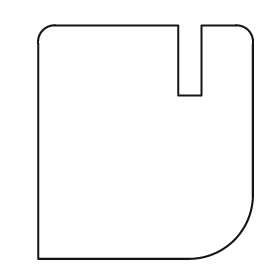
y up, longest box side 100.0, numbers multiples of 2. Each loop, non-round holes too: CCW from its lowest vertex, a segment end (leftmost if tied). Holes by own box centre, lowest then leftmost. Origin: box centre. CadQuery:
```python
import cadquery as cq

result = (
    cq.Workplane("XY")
    .moveTo(-46.0, -50.0)
    .lineTo(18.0, -50.0)
    .threePointArc((38.0, -42.0), (46.0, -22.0))
    .lineTo(46.0, 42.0)
    .threePointArc((44.0, 48.0), (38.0, 50.0))
    .lineTo(24.0, 50.0)
    .lineTo(24.0, 20.0)
    .lineTo(14.0, 20.0)
    .lineTo(14.0, 50.0)
    .lineTo(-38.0, 50.0)
    .threePointArc((-44.0, 48.0), (-46.0, 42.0))
    .close()
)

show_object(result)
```